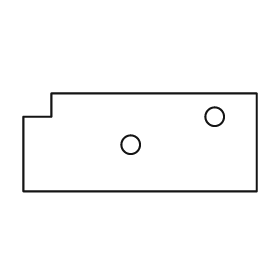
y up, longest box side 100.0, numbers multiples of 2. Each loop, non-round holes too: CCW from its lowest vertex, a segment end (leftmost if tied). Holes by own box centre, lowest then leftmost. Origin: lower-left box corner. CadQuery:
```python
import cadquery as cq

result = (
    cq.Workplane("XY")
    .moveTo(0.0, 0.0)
    .lineTo(100.0, 0.0)
    .lineTo(100.0, 42.0)
    .lineTo(12.0, 42.0)
    .lineTo(12.0, 32.0)
    .lineTo(0.0, 32.0)
    .close()
    .moveTo(46.0, 20.0)
    .circle(4.0)
    .moveTo(82.0, 32.0)
    .circle(4.0)
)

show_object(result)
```